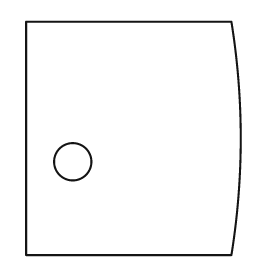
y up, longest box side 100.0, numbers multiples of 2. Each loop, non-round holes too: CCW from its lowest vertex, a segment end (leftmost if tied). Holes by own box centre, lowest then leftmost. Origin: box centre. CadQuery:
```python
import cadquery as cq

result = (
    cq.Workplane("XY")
    .moveTo(-46.0, -50.0)
    .lineTo(42.0, -50.0)
    .threePointArc((46.0, 0.0), (42.0, 50.0))
    .lineTo(-46.0, 50.0)
    .close()
    .moveTo(-26.0, -10.0)
    .circle(8.0)
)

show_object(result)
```